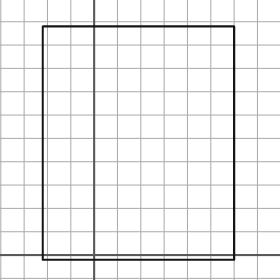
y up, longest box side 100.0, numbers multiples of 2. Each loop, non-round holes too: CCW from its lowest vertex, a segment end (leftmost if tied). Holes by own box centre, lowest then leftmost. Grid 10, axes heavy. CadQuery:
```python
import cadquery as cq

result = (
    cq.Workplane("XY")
    .moveTo(-22.0, -2.0)
    .lineTo(60.0, -2.0)
    .lineTo(60.0, 98.0)
    .lineTo(-22.0, 98.0)
    .close()
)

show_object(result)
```